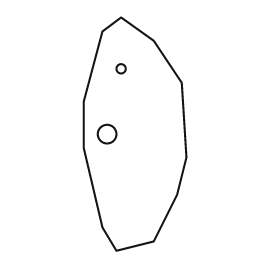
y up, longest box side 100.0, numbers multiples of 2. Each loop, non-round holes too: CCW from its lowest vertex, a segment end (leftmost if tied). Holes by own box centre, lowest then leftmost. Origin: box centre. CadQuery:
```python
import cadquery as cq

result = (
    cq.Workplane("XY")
    .moveTo(-8.0, -50.0)
    .lineTo(8.0, -46.0)
    .lineTo(18.0, -26.0)
    .lineTo(22.0, -10.0)
    .lineTo(20.0, 22.0)
    .lineTo(8.0, 40.0)
    .lineTo(-6.0, 50.0)
    .lineTo(-14.0, 44.0)
    .lineTo(-22.0, 14.0)
    .lineTo(-22.0, -6.0)
    .lineTo(-14.0, -40.0)
    .close()
    .moveTo(-12.0, 0.0)
    .circle(4.0)
    .moveTo(-6.0, 28.0)
    .circle(2.0)
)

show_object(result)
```